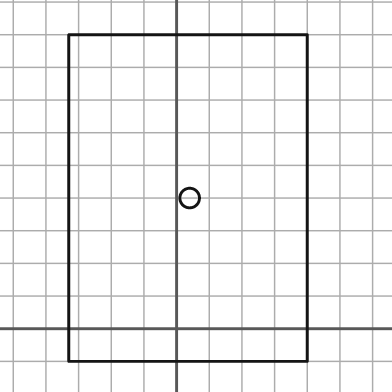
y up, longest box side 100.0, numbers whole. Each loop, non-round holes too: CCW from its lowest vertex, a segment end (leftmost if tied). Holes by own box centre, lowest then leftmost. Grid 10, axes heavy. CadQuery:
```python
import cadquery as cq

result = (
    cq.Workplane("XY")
    .moveTo(-33.0, -10.0)
    .lineTo(40.0, -10.0)
    .lineTo(40.0, 90.0)
    .lineTo(-33.0, 90.0)
    .close()
    .moveTo(4.0, 40.0)
    .circle(3.0)
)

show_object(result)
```